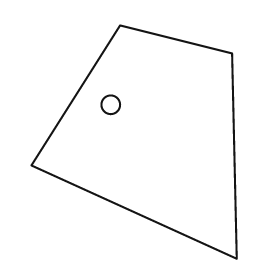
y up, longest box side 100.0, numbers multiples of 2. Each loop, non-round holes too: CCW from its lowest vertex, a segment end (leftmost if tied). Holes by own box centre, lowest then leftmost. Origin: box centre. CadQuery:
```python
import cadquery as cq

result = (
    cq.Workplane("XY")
    .moveTo(44.0, -50.0)
    .lineTo(42.0, 38.0)
    .lineTo(-6.0, 50.0)
    .lineTo(-44.0, -10.0)
    .close()
    .moveTo(-10.0, 16.0)
    .circle(4.0)
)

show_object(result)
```